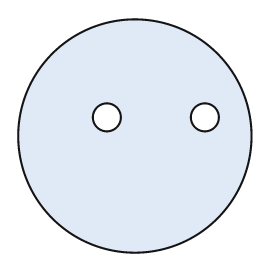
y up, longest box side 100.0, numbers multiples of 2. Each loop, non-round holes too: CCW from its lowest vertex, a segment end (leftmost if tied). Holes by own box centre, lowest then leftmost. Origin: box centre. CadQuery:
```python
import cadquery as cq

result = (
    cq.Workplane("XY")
    .moveTo(0.0, 0.0)
    .circle(50.0)
    .moveTo(-12.0, 8.0)
    .circle(6.0)
    .moveTo(30.0, 8.0)
    .circle(6.0)
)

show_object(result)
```